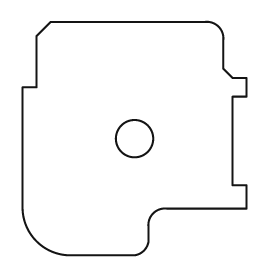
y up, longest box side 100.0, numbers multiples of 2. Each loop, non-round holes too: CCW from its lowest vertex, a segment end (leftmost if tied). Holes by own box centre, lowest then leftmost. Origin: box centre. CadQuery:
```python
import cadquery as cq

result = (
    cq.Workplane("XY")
    .moveTo(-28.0, -50.0)
    .lineTo(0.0, -50.0)
    .threePointArc((4.0, -48.0), (6.0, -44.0))
    .lineTo(6.0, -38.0)
    .threePointArc((8.0, -32.0), (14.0, -30.0))
    .lineTo(48.0, -30.0)
    .lineTo(48.0, -20.0)
    .lineTo(42.0, -20.0)
    .lineTo(42.0, 18.0)
    .lineTo(48.0, 18.0)
    .lineTo(48.0, 26.0)
    .lineTo(42.0, 26.0)
    .lineTo(38.0, 30.0)
    .lineTo(38.0, 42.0)
    .threePointArc((36.0, 48.0), (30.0, 50.0))
    .lineTo(-36.0, 50.0)
    .lineTo(-42.0, 44.0)
    .lineTo(-42.0, 22.0)
    .lineTo(-48.0, 22.0)
    .lineTo(-48.0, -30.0)
    .threePointArc((-42.0, -44.0), (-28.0, -50.0))
    .close()
    .moveTo(0.0, 0.0)
    .circle(8.0)
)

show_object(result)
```